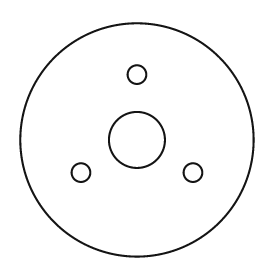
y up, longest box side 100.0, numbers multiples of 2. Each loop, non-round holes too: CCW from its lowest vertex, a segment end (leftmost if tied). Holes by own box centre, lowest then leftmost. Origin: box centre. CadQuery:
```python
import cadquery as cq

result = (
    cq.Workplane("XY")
    .moveTo(0.0, 0.0)
    .circle(50.0)
    .moveTo(-24.0, -14.0)
    .circle(4.0)
    .moveTo(24.0, -14.0)
    .circle(4.0)
    .moveTo(0.0, 0.0)
    .circle(12.0)
    .moveTo(0.0, 28.0)
    .circle(4.0)
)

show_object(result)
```